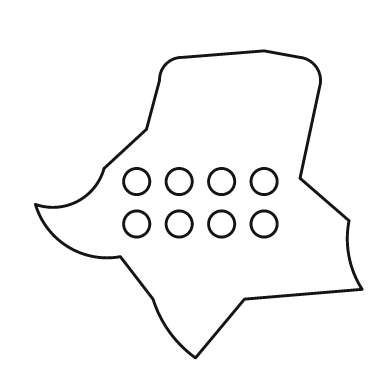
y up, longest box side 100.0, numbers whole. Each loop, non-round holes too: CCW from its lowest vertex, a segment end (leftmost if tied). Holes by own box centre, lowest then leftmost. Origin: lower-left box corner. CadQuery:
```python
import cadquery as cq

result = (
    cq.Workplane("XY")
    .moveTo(49.0, 0.0)
    .lineTo(64.0, 18.0)
    .lineTo(100.0, 21.0)
    .threePointArc((96.0, 31.0), (96.0, 42.0))
    .lineTo(81.0, 55.0)
    .lineTo(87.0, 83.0)
    .threePointArc((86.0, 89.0), (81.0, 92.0))
    .lineTo(70.0, 94.0)
    .lineTo(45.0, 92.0)
    .threePointArc((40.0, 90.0), (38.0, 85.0))
    .lineTo(34.0, 70.0)
    .lineTo(21.0, 58.0)
    .threePointArc((13.0, 48.0), (0.0, 47.0))
    .threePointArc((10.0, 34.0), (26.0, 31.0))
    .lineTo(36.0, 18.0)
    .threePointArc((41.0, 8.0), (49.0, 0.0))
    .close()
    .moveTo(31.0, 41.0)
    .circle(4.0)
    .moveTo(44.0, 41.0)
    .circle(4.0)
    .moveTo(57.0, 41.0)
    .circle(4.0)
    .moveTo(70.0, 41.0)
    .circle(4.0)
    .moveTo(31.0, 54.0)
    .circle(4.0)
    .moveTo(44.0, 54.0)
    .circle(4.0)
    .moveTo(57.0, 54.0)
    .circle(4.0)
    .moveTo(70.0, 54.0)
    .circle(4.0)
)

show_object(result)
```